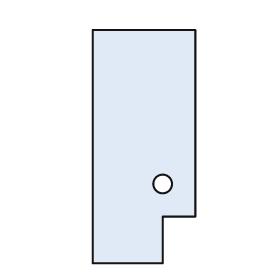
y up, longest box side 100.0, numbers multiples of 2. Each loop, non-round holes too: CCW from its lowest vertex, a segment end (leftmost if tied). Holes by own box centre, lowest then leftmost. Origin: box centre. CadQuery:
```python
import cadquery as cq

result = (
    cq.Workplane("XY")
    .moveTo(-22.0, -50.0)
    .lineTo(8.0, -50.0)
    .lineTo(8.0, -30.0)
    .lineTo(22.0, -30.0)
    .lineTo(22.0, 50.0)
    .lineTo(-22.0, 50.0)
    .close()
    .moveTo(8.0, -16.0)
    .circle(4.0)
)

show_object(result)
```